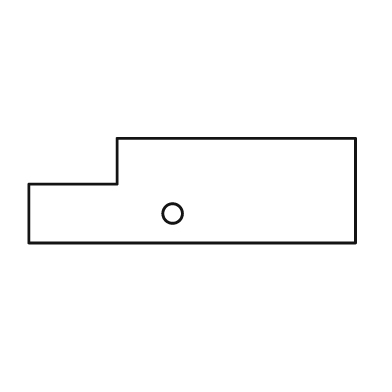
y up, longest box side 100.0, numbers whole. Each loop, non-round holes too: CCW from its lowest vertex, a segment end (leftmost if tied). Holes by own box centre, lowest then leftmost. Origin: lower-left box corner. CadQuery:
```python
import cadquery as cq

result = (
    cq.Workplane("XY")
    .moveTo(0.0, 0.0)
    .lineTo(100.0, 0.0)
    .lineTo(100.0, 32.0)
    .lineTo(27.0, 32.0)
    .lineTo(27.0, 18.0)
    .lineTo(0.0, 18.0)
    .close()
    .moveTo(44.0, 9.0)
    .circle(3.0)
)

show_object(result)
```